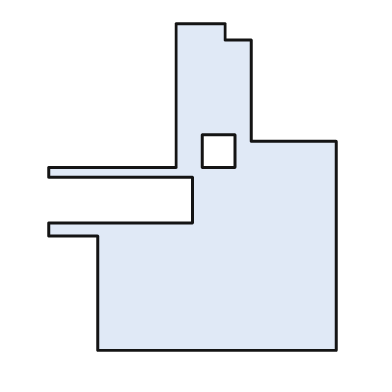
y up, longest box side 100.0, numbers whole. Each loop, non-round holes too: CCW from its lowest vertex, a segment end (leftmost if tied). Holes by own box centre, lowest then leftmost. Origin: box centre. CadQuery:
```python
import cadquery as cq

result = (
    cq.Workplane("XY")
    .moveTo(-29.0, -50.0)
    .lineTo(44.0, -50.0)
    .lineTo(44.0, 14.0)
    .lineTo(18.0, 14.0)
    .lineTo(18.0, 45.0)
    .lineTo(10.0, 45.0)
    .lineTo(10.0, 50.0)
    .lineTo(-5.0, 50.0)
    .lineTo(-5.0, 6.0)
    .lineTo(-44.0, 6.0)
    .lineTo(-44.0, 3.0)
    .lineTo(0.0, 3.0)
    .lineTo(0.0, -11.0)
    .lineTo(-44.0, -11.0)
    .lineTo(-44.0, -15.0)
    .lineTo(-29.0, -15.0)
    .close()
    .moveTo(3.0, 6.0)
    .lineTo(13.0, 6.0)
    .lineTo(13.0, 16.0)
    .lineTo(3.0, 16.0)
    .close()
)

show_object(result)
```